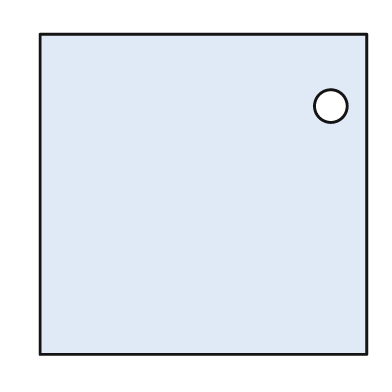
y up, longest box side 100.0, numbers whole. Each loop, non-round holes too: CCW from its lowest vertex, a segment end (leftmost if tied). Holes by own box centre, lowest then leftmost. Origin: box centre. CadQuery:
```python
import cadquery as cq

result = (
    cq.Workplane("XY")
    .moveTo(-50.0, -49.0)
    .lineTo(50.0, -49.0)
    .lineTo(50.0, 49.0)
    .lineTo(-50.0, 49.0)
    .close()
    .moveTo(39.0, 27.0)
    .circle(5.0)
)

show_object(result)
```